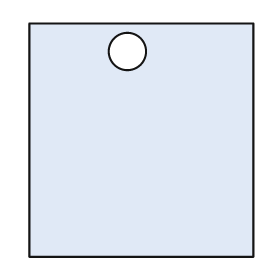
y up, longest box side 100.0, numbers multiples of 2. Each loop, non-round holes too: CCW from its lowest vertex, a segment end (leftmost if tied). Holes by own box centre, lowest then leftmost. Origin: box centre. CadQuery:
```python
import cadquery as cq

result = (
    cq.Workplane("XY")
    .moveTo(-48.0, -50.0)
    .lineTo(48.0, -50.0)
    .lineTo(48.0, 50.0)
    .lineTo(-48.0, 50.0)
    .close()
    .moveTo(-6.0, 38.0)
    .circle(8.0)
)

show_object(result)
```